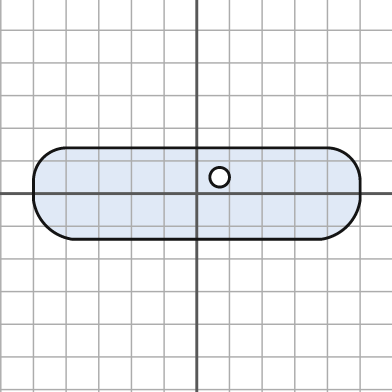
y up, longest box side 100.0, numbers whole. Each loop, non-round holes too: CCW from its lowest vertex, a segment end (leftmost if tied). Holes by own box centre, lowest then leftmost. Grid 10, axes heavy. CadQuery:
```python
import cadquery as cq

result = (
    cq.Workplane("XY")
    .moveTo(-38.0, -14.0)
    .lineTo(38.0, -14.0)
    .threePointArc((46.0, -10.0), (50.0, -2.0))
    .lineTo(50.0, 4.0)
    .threePointArc((47.0, 11.0), (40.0, 14.0))
    .lineTo(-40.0, 14.0)
    .threePointArc((-47.0, 11.0), (-50.0, 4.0))
    .lineTo(-50.0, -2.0)
    .threePointArc((-46.0, -10.0), (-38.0, -14.0))
    .close()
    .moveTo(7.0, 5.0)
    .circle(3.0)
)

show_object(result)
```